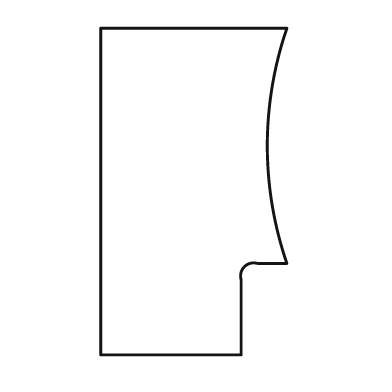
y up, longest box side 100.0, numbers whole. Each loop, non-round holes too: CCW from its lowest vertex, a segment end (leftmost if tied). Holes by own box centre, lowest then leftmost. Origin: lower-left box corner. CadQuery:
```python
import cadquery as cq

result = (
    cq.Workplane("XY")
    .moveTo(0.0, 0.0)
    .lineTo(43.0, 0.0)
    .lineTo(43.0, 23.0)
    .threePointArc((44.0, 27.0), (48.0, 28.0))
    .lineTo(57.0, 28.0)
    .threePointArc((51.0, 64.0), (57.0, 100.0))
    .lineTo(0.0, 100.0)
    .close()
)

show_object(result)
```